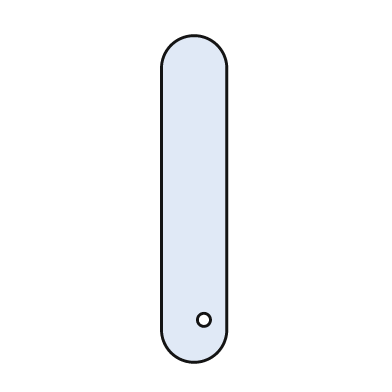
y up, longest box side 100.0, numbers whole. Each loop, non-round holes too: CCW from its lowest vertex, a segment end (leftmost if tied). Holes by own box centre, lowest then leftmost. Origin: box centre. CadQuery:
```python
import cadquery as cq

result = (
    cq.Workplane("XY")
    .moveTo(-10.0, -40.0)
    .threePointArc((0.0, -50.0), (10.0, -40.0))
    .lineTo(10.0, 40.0)
    .threePointArc((0.0, 50.0), (-10.0, 40.0))
    .close()
    .moveTo(3.0, -37.0)
    .circle(2.0)
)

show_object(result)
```